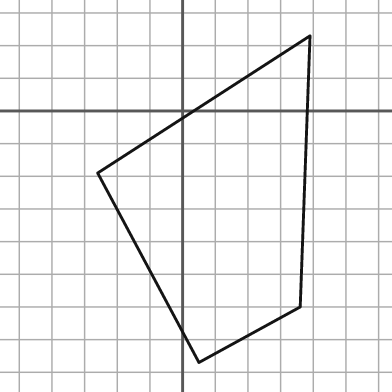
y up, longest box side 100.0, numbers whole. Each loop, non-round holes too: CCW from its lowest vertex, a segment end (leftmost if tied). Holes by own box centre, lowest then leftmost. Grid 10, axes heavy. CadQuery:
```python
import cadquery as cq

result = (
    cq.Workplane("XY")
    .moveTo(5.0, -77.0)
    .lineTo(36.0, -60.0)
    .lineTo(39.0, 23.0)
    .lineTo(-26.0, -19.0)
    .close()
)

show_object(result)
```